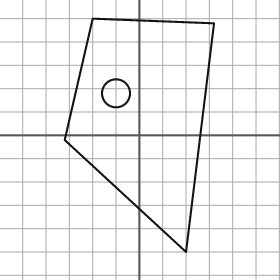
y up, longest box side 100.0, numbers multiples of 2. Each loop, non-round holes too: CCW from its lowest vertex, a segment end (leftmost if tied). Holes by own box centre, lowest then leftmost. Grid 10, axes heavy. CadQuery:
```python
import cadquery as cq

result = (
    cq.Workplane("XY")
    .moveTo(20.0, -50.0)
    .lineTo(32.0, 48.0)
    .lineTo(-20.0, 50.0)
    .lineTo(-32.0, -2.0)
    .close()
    .moveTo(-10.0, 18.0)
    .circle(6.0)
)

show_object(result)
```